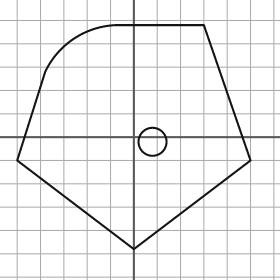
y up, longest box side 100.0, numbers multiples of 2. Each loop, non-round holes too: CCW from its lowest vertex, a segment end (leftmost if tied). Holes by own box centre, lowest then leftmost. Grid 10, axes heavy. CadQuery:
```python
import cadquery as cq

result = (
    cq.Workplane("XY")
    .moveTo(0.0, -48.0)
    .lineTo(50.0, -10.0)
    .lineTo(30.0, 48.0)
    .lineTo(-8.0, 48.0)
    .threePointArc((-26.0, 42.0), (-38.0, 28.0))
    .lineTo(-50.0, -10.0)
    .close()
    .moveTo(8.0, -2.0)
    .circle(6.0)
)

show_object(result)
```